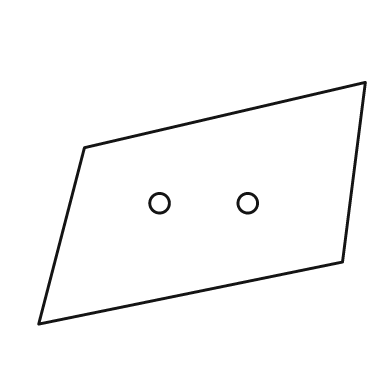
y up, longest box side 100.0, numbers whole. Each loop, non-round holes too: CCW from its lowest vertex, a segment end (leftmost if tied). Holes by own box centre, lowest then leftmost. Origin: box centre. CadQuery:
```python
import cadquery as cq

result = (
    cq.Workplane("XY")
    .moveTo(-50.0, -37.0)
    .lineTo(43.0, -18.0)
    .lineTo(50.0, 37.0)
    .lineTo(-36.0, 17.0)
    .close()
    .moveTo(-13.0, 0.0)
    .circle(3.0)
    .moveTo(14.0, 0.0)
    .circle(3.0)
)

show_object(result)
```